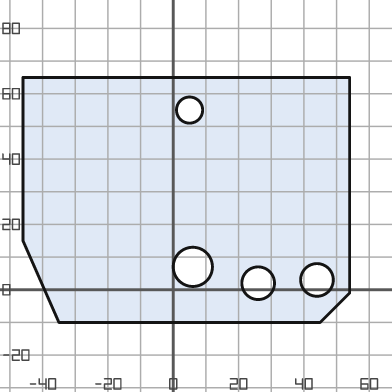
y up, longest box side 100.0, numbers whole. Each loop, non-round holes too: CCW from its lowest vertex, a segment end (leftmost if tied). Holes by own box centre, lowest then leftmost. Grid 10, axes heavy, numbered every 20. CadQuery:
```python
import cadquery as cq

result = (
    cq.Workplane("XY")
    .moveTo(-35.0, -10.0)
    .lineTo(45.0, -10.0)
    .lineTo(54.0, -1.0)
    .lineTo(54.0, 65.0)
    .lineTo(-46.0, 65.0)
    .lineTo(-46.0, 15.0)
    .close()
    .moveTo(26.0, 2.0)
    .circle(5.0)
    .moveTo(44.0, 3.0)
    .circle(5.0)
    .moveTo(6.0, 7.0)
    .circle(6.0)
    .moveTo(5.0, 55.0)
    .circle(4.0)
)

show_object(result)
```